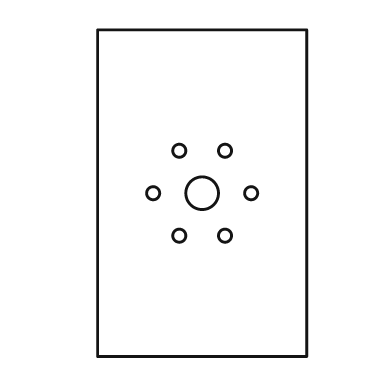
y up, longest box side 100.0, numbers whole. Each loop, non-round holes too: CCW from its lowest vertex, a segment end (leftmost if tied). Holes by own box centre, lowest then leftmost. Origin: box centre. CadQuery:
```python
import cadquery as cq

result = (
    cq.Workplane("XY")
    .moveTo(-32.0, -50.0)
    .lineTo(32.0, -50.0)
    .lineTo(32.0, 50.0)
    .lineTo(-32.0, 50.0)
    .close()
    .moveTo(-7.0, -13.0)
    .circle(2.0)
    .moveTo(7.0, -13.0)
    .circle(2.0)
    .moveTo(-15.0, 0.0)
    .circle(2.0)
    .moveTo(0.0, 0.0)
    .circle(5.0)
    .moveTo(15.0, 0.0)
    .circle(2.0)
    .moveTo(-7.0, 13.0)
    .circle(2.0)
    .moveTo(7.0, 13.0)
    .circle(2.0)
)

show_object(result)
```